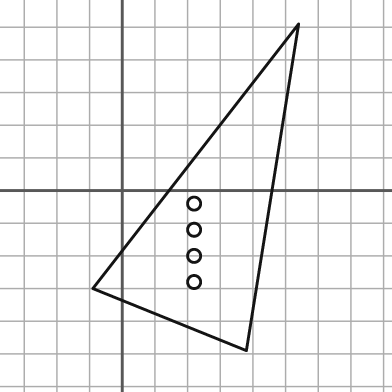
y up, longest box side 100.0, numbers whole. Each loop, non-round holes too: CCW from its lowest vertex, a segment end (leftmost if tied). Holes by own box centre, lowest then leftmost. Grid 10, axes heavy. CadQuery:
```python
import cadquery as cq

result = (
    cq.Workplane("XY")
    .moveTo(38.0, -49.0)
    .lineTo(54.0, 51.0)
    .lineTo(-9.0, -30.0)
    .close()
    .moveTo(22.0, -28.0)
    .circle(2.0)
    .moveTo(22.0, -20.0)
    .circle(2.0)
    .moveTo(22.0, -12.0)
    .circle(2.0)
    .moveTo(22.0, -4.0)
    .circle(2.0)
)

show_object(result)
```